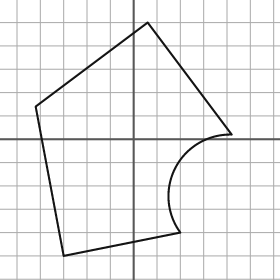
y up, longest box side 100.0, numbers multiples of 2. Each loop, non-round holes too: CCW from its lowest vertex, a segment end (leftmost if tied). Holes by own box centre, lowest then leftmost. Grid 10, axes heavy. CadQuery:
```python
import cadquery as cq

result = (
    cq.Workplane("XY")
    .moveTo(-30.0, -50.0)
    .lineTo(20.0, -40.0)
    .threePointArc((18.0, -12.0), (42.0, 2.0))
    .lineTo(6.0, 50.0)
    .lineTo(-42.0, 14.0)
    .close()
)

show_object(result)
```